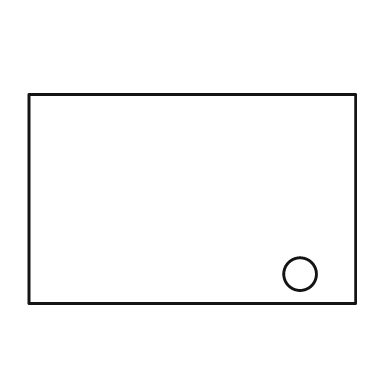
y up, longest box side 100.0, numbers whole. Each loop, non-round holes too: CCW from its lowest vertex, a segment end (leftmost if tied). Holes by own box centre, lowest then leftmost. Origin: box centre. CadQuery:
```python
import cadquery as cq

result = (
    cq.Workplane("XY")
    .moveTo(-50.0, -32.0)
    .lineTo(50.0, -32.0)
    .lineTo(50.0, 32.0)
    .lineTo(-50.0, 32.0)
    .close()
    .moveTo(33.0, -23.0)
    .circle(5.0)
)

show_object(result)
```